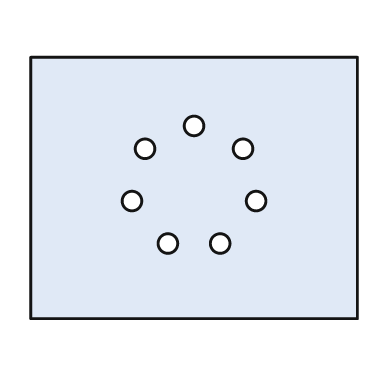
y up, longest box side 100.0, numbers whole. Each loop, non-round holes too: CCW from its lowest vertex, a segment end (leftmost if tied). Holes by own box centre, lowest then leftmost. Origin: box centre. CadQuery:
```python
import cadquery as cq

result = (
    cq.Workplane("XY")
    .moveTo(-50.0, -40.0)
    .lineTo(50.0, -40.0)
    .lineTo(50.0, 40.0)
    .lineTo(-50.0, 40.0)
    .close()
    .moveTo(-8.0, -17.0)
    .circle(3.0)
    .moveTo(8.0, -17.0)
    .circle(3.0)
    .moveTo(-19.0, -4.0)
    .circle(3.0)
    .moveTo(19.0, -4.0)
    .circle(3.0)
    .moveTo(-15.0, 12.0)
    .circle(3.0)
    .moveTo(15.0, 12.0)
    .circle(3.0)
    .moveTo(0.0, 19.0)
    .circle(3.0)
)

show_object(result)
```